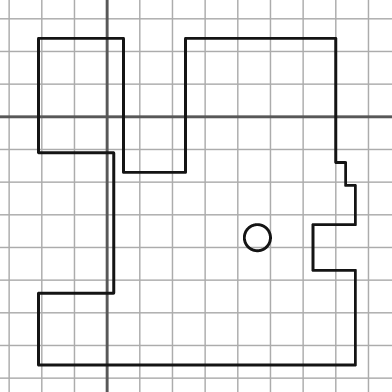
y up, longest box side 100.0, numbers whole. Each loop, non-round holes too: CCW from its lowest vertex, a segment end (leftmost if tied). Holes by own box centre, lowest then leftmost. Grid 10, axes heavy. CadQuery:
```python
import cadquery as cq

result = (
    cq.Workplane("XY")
    .moveTo(-21.0, -76.0)
    .lineTo(76.0, -76.0)
    .lineTo(76.0, -47.0)
    .lineTo(63.0, -47.0)
    .lineTo(63.0, -33.0)
    .lineTo(76.0, -33.0)
    .lineTo(76.0, -21.0)
    .lineTo(73.0, -21.0)
    .lineTo(73.0, -14.0)
    .lineTo(70.0, -14.0)
    .lineTo(70.0, 24.0)
    .lineTo(24.0, 24.0)
    .lineTo(24.0, -17.0)
    .lineTo(5.0, -17.0)
    .lineTo(5.0, 24.0)
    .lineTo(-21.0, 24.0)
    .lineTo(-21.0, -11.0)
    .lineTo(2.0, -11.0)
    .lineTo(2.0, -54.0)
    .lineTo(-21.0, -54.0)
    .close()
    .moveTo(46.0, -37.0)
    .circle(4.0)
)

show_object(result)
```